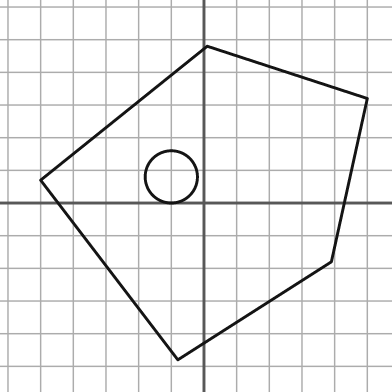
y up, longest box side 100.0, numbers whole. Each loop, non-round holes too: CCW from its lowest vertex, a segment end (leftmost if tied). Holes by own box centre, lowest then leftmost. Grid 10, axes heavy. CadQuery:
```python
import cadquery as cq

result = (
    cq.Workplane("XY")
    .moveTo(-8.0, -48.0)
    .lineTo(39.0, -18.0)
    .lineTo(50.0, 32.0)
    .lineTo(1.0, 48.0)
    .lineTo(-50.0, 7.0)
    .close()
    .moveTo(-10.0, 8.0)
    .circle(8.0)
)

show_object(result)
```